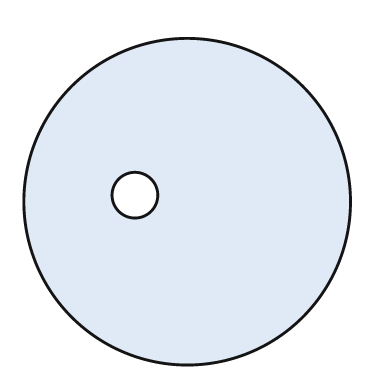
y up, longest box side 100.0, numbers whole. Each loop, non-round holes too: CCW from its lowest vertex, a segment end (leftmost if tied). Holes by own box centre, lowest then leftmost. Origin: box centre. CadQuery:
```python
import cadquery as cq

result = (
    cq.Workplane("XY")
    .moveTo(0.0, 0.0)
    .circle(50.0)
    .moveTo(-16.0, 2.0)
    .circle(7.0)
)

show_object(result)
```